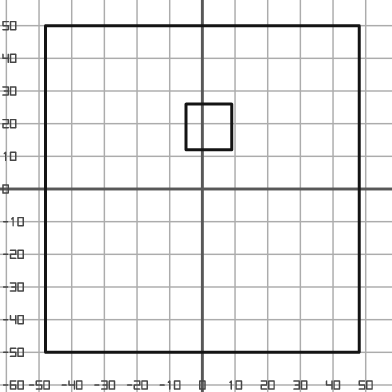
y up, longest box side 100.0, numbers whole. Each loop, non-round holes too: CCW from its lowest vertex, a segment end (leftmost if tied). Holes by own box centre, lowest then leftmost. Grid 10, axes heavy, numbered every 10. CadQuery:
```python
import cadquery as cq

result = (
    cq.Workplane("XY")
    .moveTo(-48.0, -50.0)
    .lineTo(48.0, -50.0)
    .lineTo(48.0, 50.0)
    .lineTo(-48.0, 50.0)
    .close()
    .moveTo(-5.0, 12.0)
    .lineTo(9.0, 12.0)
    .lineTo(9.0, 26.0)
    .lineTo(-5.0, 26.0)
    .close()
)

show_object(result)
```